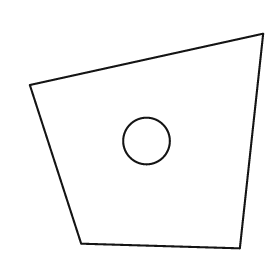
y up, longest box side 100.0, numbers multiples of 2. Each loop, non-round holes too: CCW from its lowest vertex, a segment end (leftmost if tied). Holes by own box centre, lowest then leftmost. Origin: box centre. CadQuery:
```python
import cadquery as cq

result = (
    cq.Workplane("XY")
    .moveTo(40.0, -46.0)
    .lineTo(50.0, 46.0)
    .lineTo(-50.0, 24.0)
    .lineTo(-28.0, -44.0)
    .close()
    .moveTo(0.0, 0.0)
    .circle(10.0)
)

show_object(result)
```